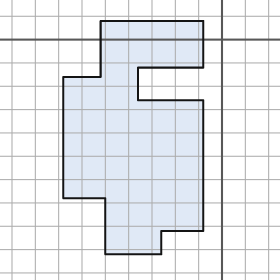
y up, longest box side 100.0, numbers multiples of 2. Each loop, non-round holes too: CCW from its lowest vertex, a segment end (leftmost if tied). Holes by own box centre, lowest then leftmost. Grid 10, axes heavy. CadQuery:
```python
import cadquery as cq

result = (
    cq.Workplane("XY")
    .moveTo(-50.0, -92.0)
    .lineTo(-26.0, -92.0)
    .lineTo(-26.0, -82.0)
    .lineTo(-8.0, -82.0)
    .lineTo(-8.0, -26.0)
    .lineTo(-36.0, -26.0)
    .lineTo(-36.0, -12.0)
    .lineTo(-8.0, -12.0)
    .lineTo(-8.0, 8.0)
    .lineTo(-52.0, 8.0)
    .lineTo(-52.0, -16.0)
    .lineTo(-68.0, -16.0)
    .lineTo(-68.0, -68.0)
    .lineTo(-50.0, -68.0)
    .close()
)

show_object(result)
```